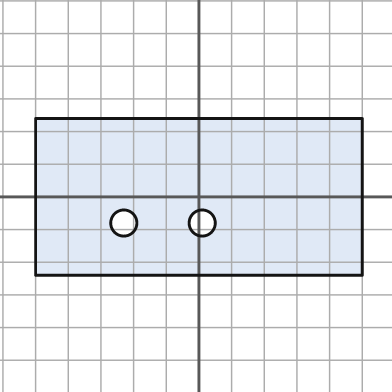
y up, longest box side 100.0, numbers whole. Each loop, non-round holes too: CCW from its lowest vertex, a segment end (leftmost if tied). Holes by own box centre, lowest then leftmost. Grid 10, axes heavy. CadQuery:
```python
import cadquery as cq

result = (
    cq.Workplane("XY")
    .moveTo(-50.0, -24.0)
    .lineTo(50.0, -24.0)
    .lineTo(50.0, 24.0)
    .lineTo(-50.0, 24.0)
    .close()
    .moveTo(-23.0, -8.0)
    .circle(4.0)
    .moveTo(1.0, -8.0)
    .circle(4.0)
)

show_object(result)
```